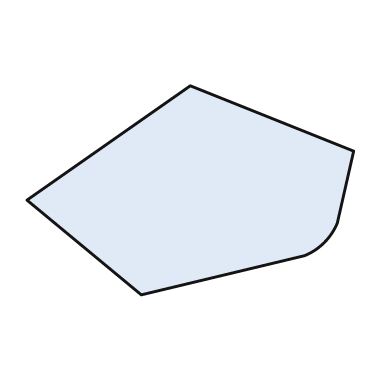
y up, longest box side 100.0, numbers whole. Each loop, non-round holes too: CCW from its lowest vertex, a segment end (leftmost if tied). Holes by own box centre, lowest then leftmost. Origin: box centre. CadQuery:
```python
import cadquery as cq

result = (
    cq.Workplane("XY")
    .moveTo(-15.0, -32.0)
    .lineTo(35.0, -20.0)
    .threePointArc((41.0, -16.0), (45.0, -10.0))
    .lineTo(50.0, 12.0)
    .lineTo(0.0, 32.0)
    .lineTo(-50.0, -3.0)
    .close()
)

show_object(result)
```